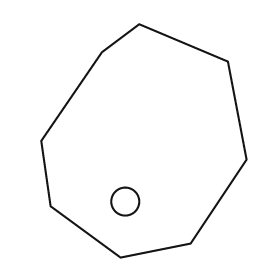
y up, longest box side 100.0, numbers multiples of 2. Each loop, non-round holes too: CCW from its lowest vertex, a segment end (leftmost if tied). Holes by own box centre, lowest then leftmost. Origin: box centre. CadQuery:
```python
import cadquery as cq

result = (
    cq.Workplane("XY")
    .moveTo(-10.0, -50.0)
    .lineTo(20.0, -44.0)
    .lineTo(44.0, -8.0)
    .lineTo(36.0, 34.0)
    .lineTo(-2.0, 50.0)
    .lineTo(-18.0, 38.0)
    .lineTo(-44.0, 0.0)
    .lineTo(-40.0, -28.0)
    .close()
    .moveTo(-8.0, -26.0)
    .circle(6.0)
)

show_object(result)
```